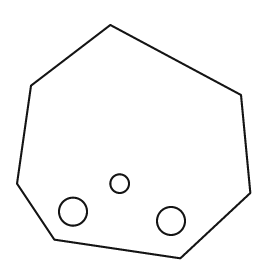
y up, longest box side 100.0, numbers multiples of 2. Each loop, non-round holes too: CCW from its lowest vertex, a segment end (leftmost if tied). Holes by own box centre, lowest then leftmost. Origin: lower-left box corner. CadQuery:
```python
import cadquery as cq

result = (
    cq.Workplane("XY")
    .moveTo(70.0, 0.0)
    .lineTo(100.0, 28.0)
    .lineTo(96.0, 70.0)
    .lineTo(40.0, 100.0)
    .lineTo(6.0, 74.0)
    .lineTo(0.0, 32.0)
    .lineTo(16.0, 8.0)
    .close()
    .moveTo(66.0, 16.0)
    .circle(6.0)
    .moveTo(24.0, 20.0)
    .circle(6.0)
    .moveTo(44.0, 32.0)
    .circle(4.0)
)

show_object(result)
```